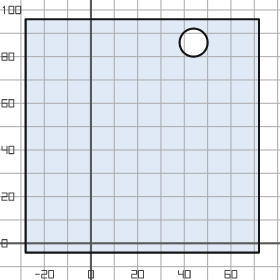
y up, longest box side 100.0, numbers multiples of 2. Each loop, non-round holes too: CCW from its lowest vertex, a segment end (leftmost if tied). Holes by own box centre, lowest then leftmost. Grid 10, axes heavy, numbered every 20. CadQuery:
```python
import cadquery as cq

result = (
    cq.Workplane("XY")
    .moveTo(-28.0, -4.0)
    .lineTo(72.0, -4.0)
    .lineTo(72.0, 96.0)
    .lineTo(-28.0, 96.0)
    .close()
    .moveTo(44.0, 86.0)
    .circle(6.0)
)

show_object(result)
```